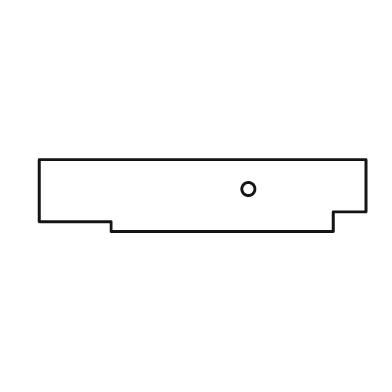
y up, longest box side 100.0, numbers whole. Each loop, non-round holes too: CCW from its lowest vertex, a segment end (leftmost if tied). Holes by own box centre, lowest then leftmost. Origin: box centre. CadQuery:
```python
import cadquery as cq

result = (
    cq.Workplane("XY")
    .moveTo(-28.0, -11.0)
    .lineTo(40.0, -11.0)
    .lineTo(40.0, -5.0)
    .lineTo(50.0, -5.0)
    .lineTo(50.0, 11.0)
    .lineTo(-50.0, 11.0)
    .lineTo(-50.0, -8.0)
    .lineTo(-28.0, -8.0)
    .close()
    .moveTo(14.0, 2.0)
    .circle(2.0)
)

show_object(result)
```